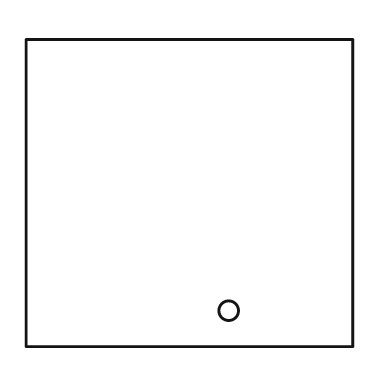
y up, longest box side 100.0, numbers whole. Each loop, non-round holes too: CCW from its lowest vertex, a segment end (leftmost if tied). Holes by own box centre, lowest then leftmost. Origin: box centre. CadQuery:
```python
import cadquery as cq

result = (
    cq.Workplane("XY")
    .moveTo(-50.0, -47.0)
    .lineTo(50.0, -47.0)
    .lineTo(50.0, 47.0)
    .lineTo(-50.0, 47.0)
    .close()
    .moveTo(12.0, -36.0)
    .circle(3.0)
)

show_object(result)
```